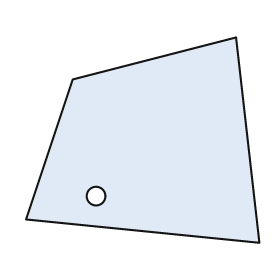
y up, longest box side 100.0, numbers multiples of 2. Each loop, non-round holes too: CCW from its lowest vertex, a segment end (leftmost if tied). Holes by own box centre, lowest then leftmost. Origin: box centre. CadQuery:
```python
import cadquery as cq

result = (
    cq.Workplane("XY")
    .moveTo(50.0, -44.0)
    .lineTo(40.0, 44.0)
    .lineTo(-30.0, 26.0)
    .lineTo(-50.0, -34.0)
    .close()
    .moveTo(-20.0, -24.0)
    .circle(4.0)
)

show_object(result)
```